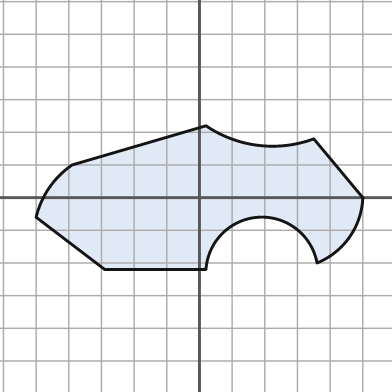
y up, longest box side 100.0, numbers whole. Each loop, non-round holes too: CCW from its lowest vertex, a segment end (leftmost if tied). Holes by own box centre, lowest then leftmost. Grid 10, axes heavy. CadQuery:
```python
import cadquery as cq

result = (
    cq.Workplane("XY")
    .moveTo(-29.0, -22.0)
    .lineTo(2.0, -22.0)
    .threePointArc((18.0, -6.0), (36.0, -20.0))
    .threePointArc((46.0, -12.0), (50.0, 0.0))
    .lineTo(35.0, 18.0)
    .threePointArc((18.0, 16.0), (2.0, 22.0))
    .lineTo(-39.0, 10.0)
    .threePointArc((-46.0, 3.0), (-50.0, -6.0))
    .close()
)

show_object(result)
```